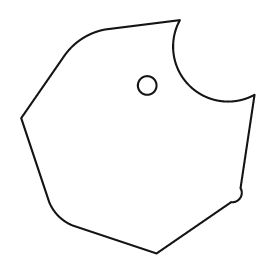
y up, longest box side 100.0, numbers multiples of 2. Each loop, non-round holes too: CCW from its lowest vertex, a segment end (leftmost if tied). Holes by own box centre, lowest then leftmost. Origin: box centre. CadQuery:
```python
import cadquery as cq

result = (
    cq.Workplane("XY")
    .moveTo(8.0, -50.0)
    .lineTo(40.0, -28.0)
    .threePointArc((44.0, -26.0), (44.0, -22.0))
    .lineTo(50.0, 18.0)
    .threePointArc((22.0, 22.0), (18.0, 50.0))
    .lineTo(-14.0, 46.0)
    .threePointArc((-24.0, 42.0), (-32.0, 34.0))
    .lineTo(-50.0, 8.0)
    .lineTo(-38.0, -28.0)
    .threePointArc((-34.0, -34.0), (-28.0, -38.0))
    .close()
    .moveTo(4.0, 22.0)
    .circle(4.0)
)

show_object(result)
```